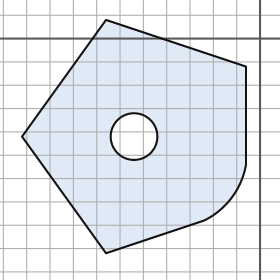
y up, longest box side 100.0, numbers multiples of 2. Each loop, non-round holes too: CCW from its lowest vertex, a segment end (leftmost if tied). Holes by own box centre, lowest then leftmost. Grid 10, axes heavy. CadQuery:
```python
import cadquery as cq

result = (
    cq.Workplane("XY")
    .moveTo(-66.0, -92.0)
    .lineTo(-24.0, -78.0)
    .threePointArc((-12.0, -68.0), (-6.0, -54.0))
    .lineTo(-6.0, -12.0)
    .lineTo(-66.0, 8.0)
    .lineTo(-102.0, -42.0)
    .close()
    .moveTo(-54.0, -42.0)
    .circle(10.0)
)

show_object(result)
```